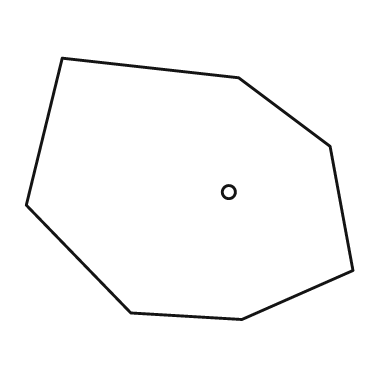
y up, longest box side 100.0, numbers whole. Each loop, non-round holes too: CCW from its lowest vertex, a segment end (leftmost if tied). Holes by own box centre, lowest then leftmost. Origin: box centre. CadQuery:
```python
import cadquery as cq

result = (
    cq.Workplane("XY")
    .moveTo(16.0, -40.0)
    .lineTo(50.0, -25.0)
    .lineTo(43.0, 13.0)
    .lineTo(15.0, 34.0)
    .lineTo(-39.0, 40.0)
    .lineTo(-50.0, -5.0)
    .lineTo(-18.0, -38.0)
    .close()
    .moveTo(12.0, -1.0)
    .circle(2.0)
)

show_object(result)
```